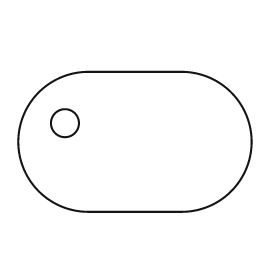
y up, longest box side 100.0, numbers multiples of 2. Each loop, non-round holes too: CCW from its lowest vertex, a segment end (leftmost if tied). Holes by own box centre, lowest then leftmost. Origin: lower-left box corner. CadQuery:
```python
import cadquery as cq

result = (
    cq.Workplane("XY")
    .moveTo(30.0, 0.0)
    .lineTo(70.0, 0.0)
    .threePointArc((100.0, 30.0), (70.0, 60.0))
    .lineTo(30.0, 60.0)
    .threePointArc((0.0, 30.0), (30.0, 0.0))
    .close()
    .moveTo(20.0, 38.0)
    .circle(6.0)
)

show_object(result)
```